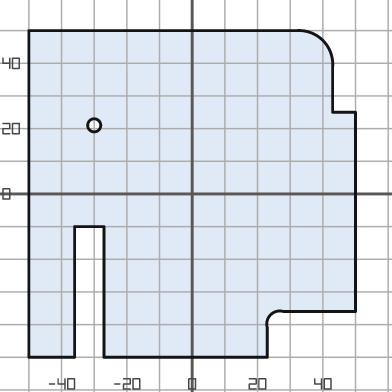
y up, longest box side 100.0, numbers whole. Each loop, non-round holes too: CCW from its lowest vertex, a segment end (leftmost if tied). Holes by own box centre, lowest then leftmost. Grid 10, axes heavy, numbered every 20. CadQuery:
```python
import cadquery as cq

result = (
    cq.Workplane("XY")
    .moveTo(-50.0, -50.0)
    .lineTo(-36.0, -50.0)
    .lineTo(-36.0, -10.0)
    .lineTo(-27.0, -10.0)
    .lineTo(-27.0, -50.0)
    .lineTo(23.0, -50.0)
    .lineTo(23.0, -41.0)
    .threePointArc((24.0, -37.0), (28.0, -36.0))
    .lineTo(50.0, -36.0)
    .lineTo(50.0, 25.0)
    .lineTo(43.0, 25.0)
    .lineTo(43.0, 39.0)
    .threePointArc((40.0, 47.0), (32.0, 50.0))
    .lineTo(-50.0, 50.0)
    .close()
    .moveTo(-30.0, 21.0)
    .circle(2.0)
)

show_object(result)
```